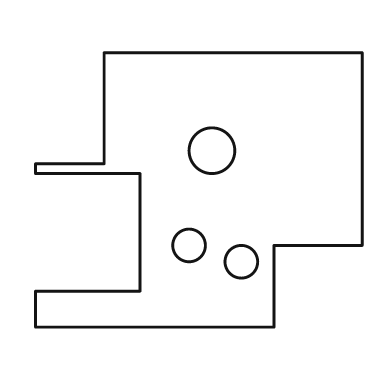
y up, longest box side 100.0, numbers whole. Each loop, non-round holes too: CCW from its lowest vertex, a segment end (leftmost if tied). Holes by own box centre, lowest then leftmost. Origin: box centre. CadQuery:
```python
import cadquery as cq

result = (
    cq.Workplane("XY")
    .moveTo(-50.0, -42.0)
    .lineTo(23.0, -42.0)
    .lineTo(23.0, -17.0)
    .lineTo(50.0, -17.0)
    .lineTo(50.0, 42.0)
    .lineTo(-29.0, 42.0)
    .lineTo(-29.0, 8.0)
    .lineTo(-50.0, 8.0)
    .lineTo(-50.0, 5.0)
    .lineTo(-18.0, 5.0)
    .lineTo(-18.0, -31.0)
    .lineTo(-50.0, -31.0)
    .close()
    .moveTo(13.0, -22.0)
    .circle(5.0)
    .moveTo(-3.0, -17.0)
    .circle(5.0)
    .moveTo(4.0, 12.0)
    .circle(7.0)
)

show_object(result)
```